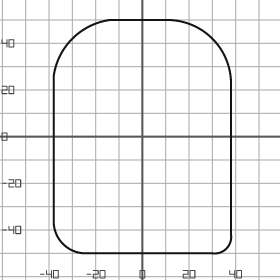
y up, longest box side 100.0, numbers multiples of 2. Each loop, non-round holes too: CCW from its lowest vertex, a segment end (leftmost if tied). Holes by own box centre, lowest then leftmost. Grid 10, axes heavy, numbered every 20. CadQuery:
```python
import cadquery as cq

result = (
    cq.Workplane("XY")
    .moveTo(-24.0, -50.0)
    .lineTo(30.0, -50.0)
    .threePointArc((36.0, -48.0), (38.0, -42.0))
    .lineTo(38.0, 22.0)
    .threePointArc((30.0, 42.0), (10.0, 50.0))
    .lineTo(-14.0, 50.0)
    .threePointArc((-30.0, 42.0), (-38.0, 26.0))
    .lineTo(-38.0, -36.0)
    .threePointArc((-34.0, -46.0), (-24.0, -50.0))
    .close()
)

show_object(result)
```